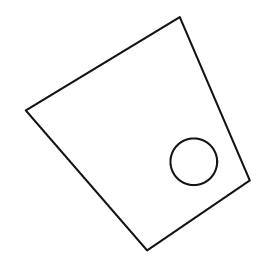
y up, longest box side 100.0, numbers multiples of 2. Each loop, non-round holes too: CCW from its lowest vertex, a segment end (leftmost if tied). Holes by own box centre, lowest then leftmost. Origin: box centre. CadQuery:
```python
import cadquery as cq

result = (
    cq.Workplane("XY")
    .moveTo(4.0, -50.0)
    .lineTo(48.0, -20.0)
    .lineTo(18.0, 50.0)
    .lineTo(-48.0, 10.0)
    .close()
    .moveTo(24.0, -12.0)
    .circle(10.0)
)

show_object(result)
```